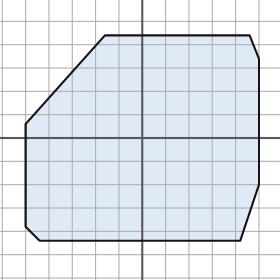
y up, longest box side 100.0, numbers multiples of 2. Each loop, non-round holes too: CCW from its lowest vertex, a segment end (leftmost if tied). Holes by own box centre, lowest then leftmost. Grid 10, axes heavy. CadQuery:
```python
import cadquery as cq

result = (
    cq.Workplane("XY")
    .moveTo(-44.0, -44.0)
    .lineTo(42.0, -44.0)
    .lineTo(50.0, -20.0)
    .lineTo(50.0, 34.0)
    .lineTo(46.0, 44.0)
    .lineTo(-16.0, 44.0)
    .lineTo(-50.0, 6.0)
    .lineTo(-50.0, -38.0)
    .close()
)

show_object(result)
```